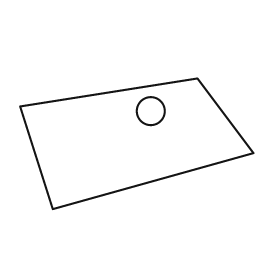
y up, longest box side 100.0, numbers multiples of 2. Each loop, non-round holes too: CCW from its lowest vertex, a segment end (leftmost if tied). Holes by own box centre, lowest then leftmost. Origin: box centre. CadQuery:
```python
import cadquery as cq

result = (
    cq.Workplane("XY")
    .moveTo(-36.0, -28.0)
    .lineTo(50.0, -4.0)
    .lineTo(26.0, 28.0)
    .lineTo(-50.0, 16.0)
    .close()
    .moveTo(6.0, 14.0)
    .circle(6.0)
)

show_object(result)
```